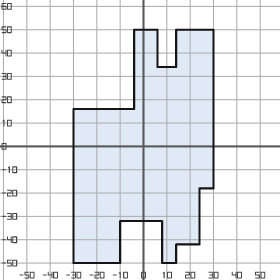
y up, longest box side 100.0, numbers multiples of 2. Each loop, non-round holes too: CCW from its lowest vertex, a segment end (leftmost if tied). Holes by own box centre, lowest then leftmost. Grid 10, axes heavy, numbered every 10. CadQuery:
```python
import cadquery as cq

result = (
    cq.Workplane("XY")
    .moveTo(-30.0, -50.0)
    .lineTo(-10.0, -50.0)
    .lineTo(-10.0, -32.0)
    .lineTo(8.0, -32.0)
    .lineTo(8.0, -50.0)
    .lineTo(14.0, -50.0)
    .lineTo(14.0, -42.0)
    .lineTo(24.0, -42.0)
    .lineTo(24.0, -18.0)
    .lineTo(30.0, -18.0)
    .lineTo(30.0, 50.0)
    .lineTo(14.0, 50.0)
    .lineTo(14.0, 34.0)
    .lineTo(6.0, 34.0)
    .lineTo(6.0, 50.0)
    .lineTo(-4.0, 50.0)
    .lineTo(-4.0, 16.0)
    .lineTo(-30.0, 16.0)
    .close()
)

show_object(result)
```